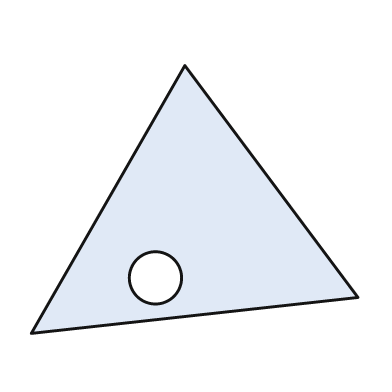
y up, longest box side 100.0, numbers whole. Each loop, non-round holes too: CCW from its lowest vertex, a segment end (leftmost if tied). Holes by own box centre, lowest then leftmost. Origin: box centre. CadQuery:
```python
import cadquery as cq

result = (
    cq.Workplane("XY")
    .moveTo(-50.0, -41.0)
    .lineTo(50.0, -30.0)
    .lineTo(-3.0, 41.0)
    .close()
    .moveTo(-12.0, -24.0)
    .circle(8.0)
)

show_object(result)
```